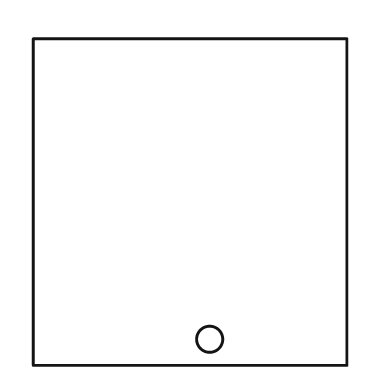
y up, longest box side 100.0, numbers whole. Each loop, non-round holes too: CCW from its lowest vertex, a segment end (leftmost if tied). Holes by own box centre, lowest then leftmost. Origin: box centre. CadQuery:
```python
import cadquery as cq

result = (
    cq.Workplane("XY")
    .moveTo(-48.0, -50.0)
    .lineTo(48.0, -50.0)
    .lineTo(48.0, 50.0)
    .lineTo(-48.0, 50.0)
    .close()
    .moveTo(6.0, -42.0)
    .circle(4.0)
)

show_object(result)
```